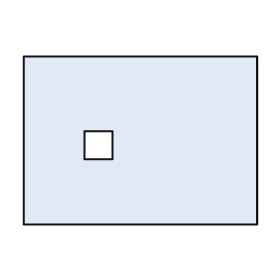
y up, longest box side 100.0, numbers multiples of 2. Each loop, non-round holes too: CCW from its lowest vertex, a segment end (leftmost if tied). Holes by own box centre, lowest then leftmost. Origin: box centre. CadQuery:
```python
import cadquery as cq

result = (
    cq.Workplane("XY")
    .moveTo(-50.0, -36.0)
    .lineTo(50.0, -36.0)
    .lineTo(50.0, 36.0)
    .lineTo(-50.0, 36.0)
    .close()
    .moveTo(-24.0, -8.0)
    .lineTo(-12.0, -8.0)
    .lineTo(-12.0, 4.0)
    .lineTo(-24.0, 4.0)
    .close()
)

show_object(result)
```